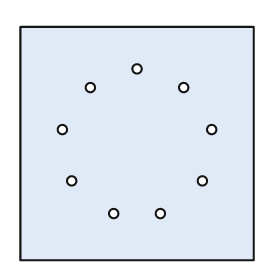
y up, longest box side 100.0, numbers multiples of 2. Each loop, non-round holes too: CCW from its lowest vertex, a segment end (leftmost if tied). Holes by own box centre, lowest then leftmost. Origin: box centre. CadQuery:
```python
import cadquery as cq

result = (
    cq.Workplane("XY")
    .moveTo(-50.0, -50.0)
    .lineTo(50.0, -50.0)
    .lineTo(50.0, 50.0)
    .lineTo(-50.0, 50.0)
    .close()
    .moveTo(-10.0, -30.0)
    .circle(2.0)
    .moveTo(10.0, -30.0)
    .circle(2.0)
    .moveTo(-28.0, -16.0)
    .circle(2.0)
    .moveTo(28.0, -16.0)
    .circle(2.0)
    .moveTo(-32.0, 6.0)
    .circle(2.0)
    .moveTo(32.0, 6.0)
    .circle(2.0)
    .moveTo(-20.0, 24.0)
    .circle(2.0)
    .moveTo(20.0, 24.0)
    .circle(2.0)
    .moveTo(0.0, 32.0)
    .circle(2.0)
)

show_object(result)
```